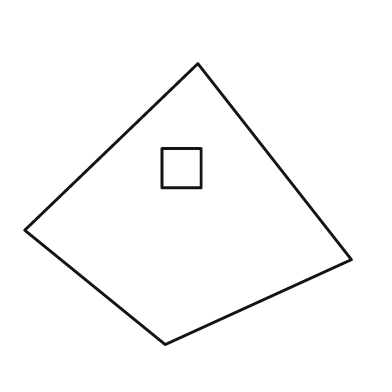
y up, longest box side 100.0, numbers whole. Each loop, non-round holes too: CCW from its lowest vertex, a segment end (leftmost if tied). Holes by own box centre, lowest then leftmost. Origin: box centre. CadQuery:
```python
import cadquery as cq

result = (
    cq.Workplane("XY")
    .moveTo(-7.0, -43.0)
    .lineTo(50.0, -17.0)
    .lineTo(3.0, 43.0)
    .lineTo(-50.0, -8.0)
    .close()
    .moveTo(-8.0, 5.0)
    .lineTo(4.0, 5.0)
    .lineTo(4.0, 17.0)
    .lineTo(-8.0, 17.0)
    .close()
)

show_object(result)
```